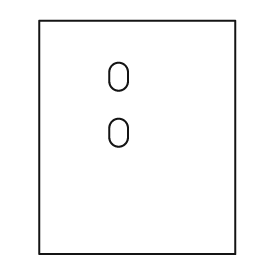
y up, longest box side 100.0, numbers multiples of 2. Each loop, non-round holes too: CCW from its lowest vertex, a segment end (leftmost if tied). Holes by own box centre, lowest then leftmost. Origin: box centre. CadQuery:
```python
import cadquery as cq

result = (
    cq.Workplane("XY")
    .moveTo(-42.0, -50.0)
    .lineTo(42.0, -50.0)
    .lineTo(42.0, 50.0)
    .lineTo(-42.0, 50.0)
    .close()
    .moveTo(-12.0, 0.0)
    .threePointArc((-8.0, -4.0), (-4.0, 0.0))
    .lineTo(-4.0, 4.0)
    .threePointArc((-8.0, 8.0), (-12.0, 4.0))
    .close()
    .moveTo(-12.0, 24.0)
    .threePointArc((-8.0, 20.0), (-4.0, 24.0))
    .lineTo(-4.0, 28.0)
    .threePointArc((-8.0, 32.0), (-12.0, 28.0))
    .close()
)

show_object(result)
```